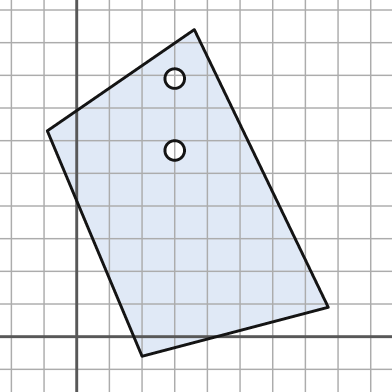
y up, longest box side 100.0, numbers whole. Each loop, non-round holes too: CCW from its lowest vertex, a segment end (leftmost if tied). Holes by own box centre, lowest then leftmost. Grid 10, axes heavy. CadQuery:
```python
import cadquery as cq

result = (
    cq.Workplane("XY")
    .moveTo(20.0, -6.0)
    .lineTo(77.0, 9.0)
    .lineTo(36.0, 94.0)
    .lineTo(-9.0, 63.0)
    .close()
    .moveTo(30.0, 57.0)
    .circle(3.0)
    .moveTo(30.0, 79.0)
    .circle(3.0)
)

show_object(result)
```